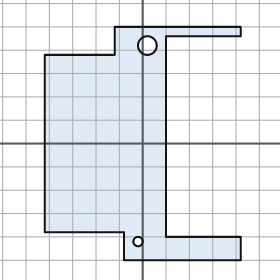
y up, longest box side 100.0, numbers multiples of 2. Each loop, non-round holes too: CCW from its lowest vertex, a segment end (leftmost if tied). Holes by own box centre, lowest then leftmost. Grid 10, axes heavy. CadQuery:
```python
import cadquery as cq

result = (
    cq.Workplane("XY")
    .moveTo(-8.0, -50.0)
    .lineTo(42.0, -50.0)
    .lineTo(42.0, -40.0)
    .lineTo(10.0, -40.0)
    .lineTo(10.0, 46.0)
    .lineTo(42.0, 46.0)
    .lineTo(42.0, 50.0)
    .lineTo(-12.0, 50.0)
    .lineTo(-12.0, 38.0)
    .lineTo(-42.0, 38.0)
    .lineTo(-42.0, -38.0)
    .lineTo(-8.0, -38.0)
    .close()
    .moveTo(-2.0, -42.0)
    .circle(2.0)
    .moveTo(2.0, 42.0)
    .circle(4.0)
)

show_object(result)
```